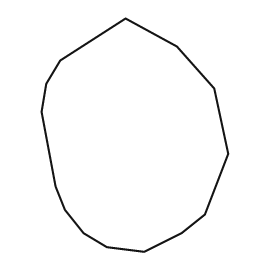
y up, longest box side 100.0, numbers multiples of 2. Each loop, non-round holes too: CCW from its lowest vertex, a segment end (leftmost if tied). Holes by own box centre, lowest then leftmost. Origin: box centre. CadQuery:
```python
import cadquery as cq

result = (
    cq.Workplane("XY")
    .moveTo(4.0, -50.0)
    .lineTo(20.0, -42.0)
    .lineTo(30.0, -34.0)
    .lineTo(40.0, -8.0)
    .lineTo(34.0, 20.0)
    .lineTo(18.0, 38.0)
    .lineTo(-4.0, 50.0)
    .lineTo(-32.0, 32.0)
    .lineTo(-38.0, 22.0)
    .lineTo(-40.0, 10.0)
    .lineTo(-34.0, -22.0)
    .lineTo(-30.0, -32.0)
    .lineTo(-22.0, -42.0)
    .lineTo(-12.0, -48.0)
    .close()
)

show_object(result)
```